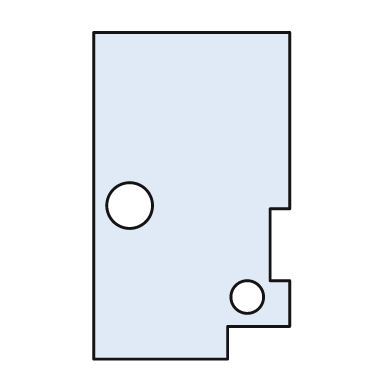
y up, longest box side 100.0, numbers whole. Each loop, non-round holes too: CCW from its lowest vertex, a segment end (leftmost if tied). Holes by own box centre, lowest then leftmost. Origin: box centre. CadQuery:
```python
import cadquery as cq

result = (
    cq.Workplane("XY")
    .moveTo(-30.0, -50.0)
    .lineTo(11.0, -50.0)
    .lineTo(11.0, -40.0)
    .lineTo(30.0, -40.0)
    .lineTo(30.0, -26.0)
    .lineTo(24.0, -26.0)
    .lineTo(24.0, -4.0)
    .lineTo(30.0, -4.0)
    .lineTo(30.0, 50.0)
    .lineTo(-30.0, 50.0)
    .close()
    .moveTo(17.0, -31.0)
    .circle(5.0)
    .moveTo(-19.0, -3.0)
    .circle(7.0)
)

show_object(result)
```